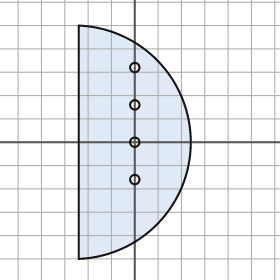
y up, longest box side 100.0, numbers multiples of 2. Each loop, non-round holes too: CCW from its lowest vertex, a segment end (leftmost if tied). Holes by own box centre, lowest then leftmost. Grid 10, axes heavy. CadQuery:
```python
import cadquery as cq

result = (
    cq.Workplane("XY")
    .moveTo(-24.0, -50.0)
    .threePointArc((24.0, 0.0), (-24.0, 50.0))
    .close()
    .moveTo(0.0, -16.0)
    .circle(2.0)
    .moveTo(0.0, 0.0)
    .circle(2.0)
    .moveTo(0.0, 16.0)
    .circle(2.0)
    .moveTo(0.0, 32.0)
    .circle(2.0)
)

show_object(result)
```